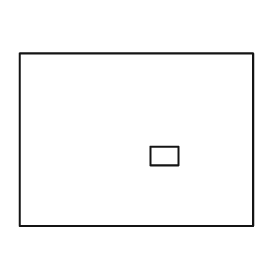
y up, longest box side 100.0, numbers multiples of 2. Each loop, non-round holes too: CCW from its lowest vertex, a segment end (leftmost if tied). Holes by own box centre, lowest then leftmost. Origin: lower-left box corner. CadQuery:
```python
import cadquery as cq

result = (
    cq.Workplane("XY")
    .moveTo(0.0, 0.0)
    .lineTo(100.0, 0.0)
    .lineTo(100.0, 74.0)
    .lineTo(0.0, 74.0)
    .close()
    .moveTo(56.0, 26.0)
    .lineTo(68.0, 26.0)
    .lineTo(68.0, 34.0)
    .lineTo(56.0, 34.0)
    .close()
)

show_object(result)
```